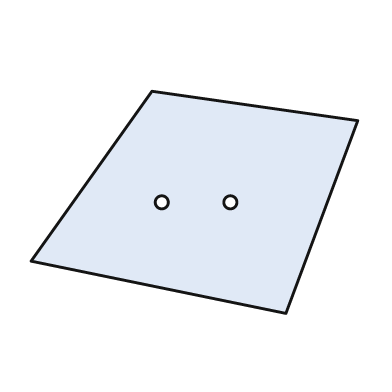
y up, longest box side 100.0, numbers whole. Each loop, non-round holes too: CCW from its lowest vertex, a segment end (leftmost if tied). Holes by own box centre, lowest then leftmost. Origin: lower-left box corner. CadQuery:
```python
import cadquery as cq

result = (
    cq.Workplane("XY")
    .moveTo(78.0, 0.0)
    .lineTo(100.0, 59.0)
    .lineTo(37.0, 68.0)
    .lineTo(0.0, 16.0)
    .close()
    .moveTo(40.0, 34.0)
    .circle(2.0)
    .moveTo(61.0, 34.0)
    .circle(2.0)
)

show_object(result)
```